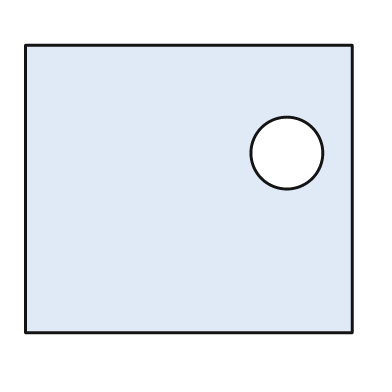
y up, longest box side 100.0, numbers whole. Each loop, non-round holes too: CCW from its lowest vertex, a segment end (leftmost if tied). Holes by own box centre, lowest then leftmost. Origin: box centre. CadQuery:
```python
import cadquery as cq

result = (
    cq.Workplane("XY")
    .moveTo(-50.0, -44.0)
    .lineTo(50.0, -44.0)
    .lineTo(50.0, 44.0)
    .lineTo(-50.0, 44.0)
    .close()
    .moveTo(30.0, 11.0)
    .circle(11.0)
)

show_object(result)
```